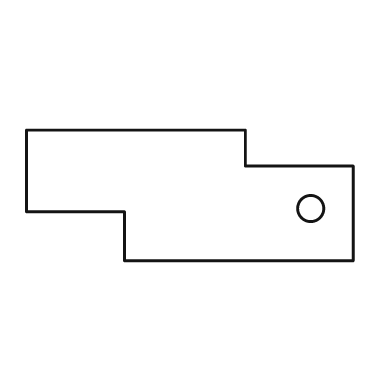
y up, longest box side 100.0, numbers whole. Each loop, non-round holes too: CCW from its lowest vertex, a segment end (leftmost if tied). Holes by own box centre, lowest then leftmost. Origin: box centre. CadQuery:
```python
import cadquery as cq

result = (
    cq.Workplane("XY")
    .moveTo(-20.0, -20.0)
    .lineTo(50.0, -20.0)
    .lineTo(50.0, 9.0)
    .lineTo(17.0, 9.0)
    .lineTo(17.0, 20.0)
    .lineTo(-50.0, 20.0)
    .lineTo(-50.0, -5.0)
    .lineTo(-20.0, -5.0)
    .close()
    .moveTo(37.0, -4.0)
    .circle(4.0)
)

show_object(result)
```